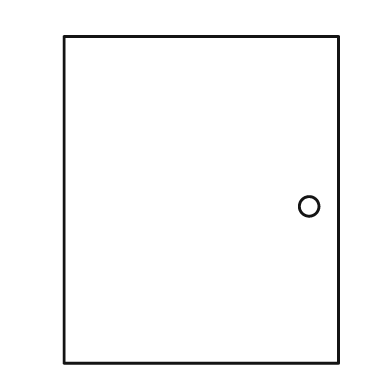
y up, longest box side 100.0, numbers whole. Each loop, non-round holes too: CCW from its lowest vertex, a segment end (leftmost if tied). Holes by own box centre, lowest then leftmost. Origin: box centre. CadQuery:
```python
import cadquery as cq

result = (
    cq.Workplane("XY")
    .moveTo(-42.0, -50.0)
    .lineTo(42.0, -50.0)
    .lineTo(42.0, 50.0)
    .lineTo(-42.0, 50.0)
    .close()
    .moveTo(33.0, -2.0)
    .circle(3.0)
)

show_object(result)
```